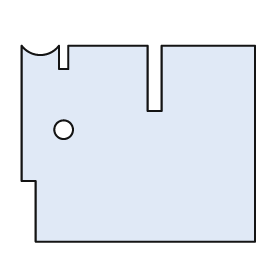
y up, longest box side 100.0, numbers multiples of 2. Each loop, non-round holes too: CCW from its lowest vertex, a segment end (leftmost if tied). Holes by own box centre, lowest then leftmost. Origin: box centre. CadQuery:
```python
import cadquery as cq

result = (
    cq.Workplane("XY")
    .moveTo(-44.0, -42.0)
    .lineTo(50.0, -42.0)
    .lineTo(50.0, 42.0)
    .lineTo(10.0, 42.0)
    .lineTo(10.0, 14.0)
    .lineTo(4.0, 14.0)
    .lineTo(4.0, 42.0)
    .lineTo(-30.0, 42.0)
    .lineTo(-30.0, 32.0)
    .lineTo(-34.0, 32.0)
    .lineTo(-34.0, 42.0)
    .threePointArc((-42.0, 38.0), (-50.0, 42.0))
    .lineTo(-50.0, -16.0)
    .lineTo(-44.0, -16.0)
    .close()
    .moveTo(-32.0, 6.0)
    .circle(4.0)
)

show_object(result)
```